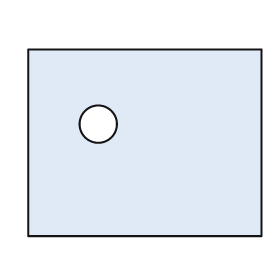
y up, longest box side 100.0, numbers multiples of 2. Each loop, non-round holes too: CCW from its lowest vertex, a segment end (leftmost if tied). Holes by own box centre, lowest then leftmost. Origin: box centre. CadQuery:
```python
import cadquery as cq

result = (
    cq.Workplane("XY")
    .moveTo(-50.0, -40.0)
    .lineTo(50.0, -40.0)
    .lineTo(50.0, 40.0)
    .lineTo(-50.0, 40.0)
    .close()
    .moveTo(-20.0, 8.0)
    .circle(8.0)
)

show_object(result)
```